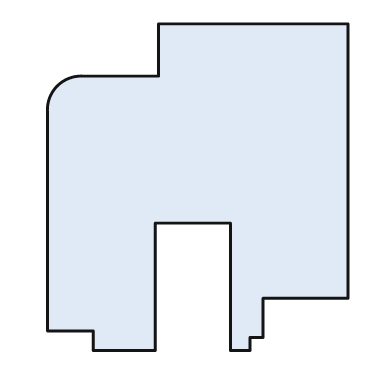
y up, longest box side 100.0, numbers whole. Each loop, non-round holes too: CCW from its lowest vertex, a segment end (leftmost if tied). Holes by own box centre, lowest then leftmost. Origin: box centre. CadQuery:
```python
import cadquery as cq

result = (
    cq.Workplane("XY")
    .moveTo(-32.0, -50.0)
    .lineTo(-13.0, -50.0)
    .lineTo(-13.0, -11.0)
    .lineTo(10.0, -11.0)
    .lineTo(10.0, -50.0)
    .lineTo(16.0, -50.0)
    .lineTo(16.0, -46.0)
    .lineTo(20.0, -46.0)
    .lineTo(20.0, -34.0)
    .lineTo(46.0, -34.0)
    .lineTo(46.0, 50.0)
    .lineTo(-12.0, 50.0)
    .lineTo(-12.0, 34.0)
    .lineTo(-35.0, 34.0)
    .threePointArc((-43.0, 31.0), (-46.0, 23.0))
    .lineTo(-46.0, -44.0)
    .lineTo(-32.0, -44.0)
    .close()
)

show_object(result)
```